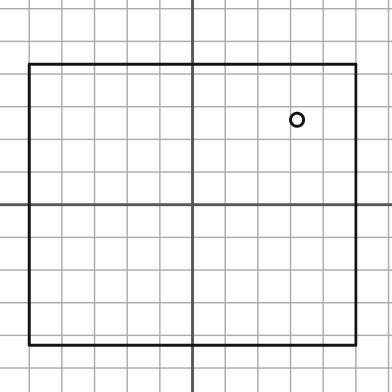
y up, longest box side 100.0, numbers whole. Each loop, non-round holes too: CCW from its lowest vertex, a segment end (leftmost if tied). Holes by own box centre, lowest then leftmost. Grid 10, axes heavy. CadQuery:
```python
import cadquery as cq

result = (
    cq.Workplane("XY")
    .moveTo(-50.0, -43.0)
    .lineTo(50.0, -43.0)
    .lineTo(50.0, 43.0)
    .lineTo(-50.0, 43.0)
    .close()
    .moveTo(32.0, 26.0)
    .circle(2.0)
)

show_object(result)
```